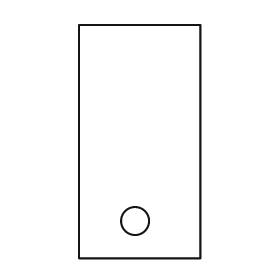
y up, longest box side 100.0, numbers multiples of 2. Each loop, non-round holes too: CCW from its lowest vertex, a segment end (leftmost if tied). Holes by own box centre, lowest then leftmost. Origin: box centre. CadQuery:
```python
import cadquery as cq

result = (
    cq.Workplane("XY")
    .moveTo(-26.0, -50.0)
    .lineTo(26.0, -50.0)
    .lineTo(26.0, 50.0)
    .lineTo(-26.0, 50.0)
    .close()
    .moveTo(-2.0, -34.0)
    .circle(6.0)
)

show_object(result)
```